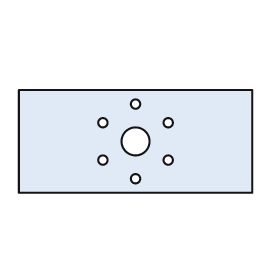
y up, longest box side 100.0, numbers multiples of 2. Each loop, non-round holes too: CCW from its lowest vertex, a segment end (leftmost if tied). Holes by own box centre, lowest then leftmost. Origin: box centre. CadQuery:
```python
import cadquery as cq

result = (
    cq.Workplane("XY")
    .moveTo(-50.0, -22.0)
    .lineTo(50.0, -22.0)
    .lineTo(50.0, 22.0)
    .lineTo(-50.0, 22.0)
    .close()
    .moveTo(0.0, -16.0)
    .circle(2.0)
    .moveTo(-14.0, -8.0)
    .circle(2.0)
    .moveTo(14.0, -8.0)
    .circle(2.0)
    .moveTo(0.0, 0.0)
    .circle(6.0)
    .moveTo(-14.0, 8.0)
    .circle(2.0)
    .moveTo(14.0, 8.0)
    .circle(2.0)
    .moveTo(0.0, 16.0)
    .circle(2.0)
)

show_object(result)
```